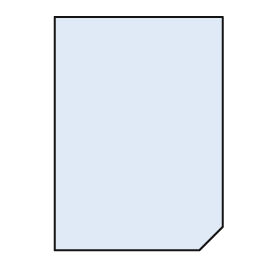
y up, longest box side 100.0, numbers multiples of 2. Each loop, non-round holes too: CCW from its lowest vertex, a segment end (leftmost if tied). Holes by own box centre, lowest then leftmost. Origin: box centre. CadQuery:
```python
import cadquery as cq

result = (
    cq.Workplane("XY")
    .moveTo(-36.0, -50.0)
    .lineTo(26.0, -50.0)
    .lineTo(36.0, -40.0)
    .lineTo(36.0, 50.0)
    .lineTo(-36.0, 50.0)
    .close()
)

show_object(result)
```